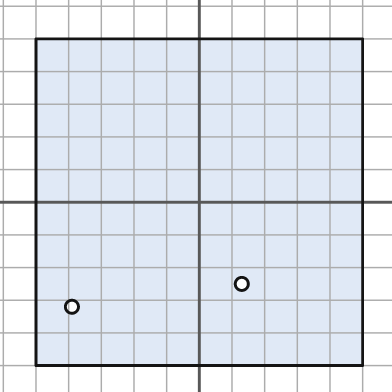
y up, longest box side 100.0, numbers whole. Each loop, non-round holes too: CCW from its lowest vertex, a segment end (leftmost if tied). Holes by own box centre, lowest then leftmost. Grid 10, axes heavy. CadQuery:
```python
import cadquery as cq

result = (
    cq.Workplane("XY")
    .moveTo(-50.0, -50.0)
    .lineTo(50.0, -50.0)
    .lineTo(50.0, 50.0)
    .lineTo(-50.0, 50.0)
    .close()
    .moveTo(-39.0, -32.0)
    .circle(2.0)
    .moveTo(13.0, -25.0)
    .circle(2.0)
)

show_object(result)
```